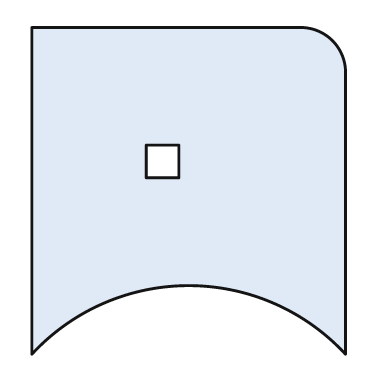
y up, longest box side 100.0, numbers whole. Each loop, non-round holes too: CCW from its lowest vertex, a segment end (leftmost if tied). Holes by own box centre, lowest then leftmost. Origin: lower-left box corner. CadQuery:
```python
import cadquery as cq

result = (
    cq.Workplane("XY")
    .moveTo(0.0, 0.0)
    .threePointArc((48.0, 21.0), (96.0, 0.0))
    .lineTo(96.0, 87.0)
    .threePointArc((92.0, 96.0), (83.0, 100.0))
    .lineTo(0.0, 100.0)
    .close()
    .moveTo(35.0, 54.0)
    .lineTo(45.0, 54.0)
    .lineTo(45.0, 64.0)
    .lineTo(35.0, 64.0)
    .close()
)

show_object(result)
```